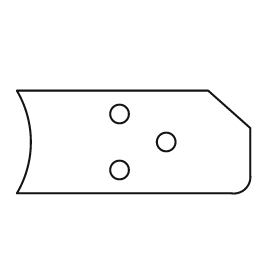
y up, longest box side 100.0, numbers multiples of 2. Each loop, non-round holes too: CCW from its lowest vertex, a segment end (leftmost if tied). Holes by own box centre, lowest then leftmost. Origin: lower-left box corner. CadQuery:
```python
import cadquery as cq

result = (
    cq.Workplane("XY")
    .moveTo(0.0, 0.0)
    .lineTo(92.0, 0.0)
    .threePointArc((98.0, 2.0), (100.0, 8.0))
    .lineTo(100.0, 28.0)
    .lineTo(82.0, 44.0)
    .lineTo(0.0, 44.0)
    .threePointArc((6.0, 22.0), (0.0, 0.0))
    .close()
    .moveTo(44.0, 10.0)
    .circle(4.0)
    .moveTo(64.0, 22.0)
    .circle(4.0)
    .moveTo(44.0, 34.0)
    .circle(4.0)
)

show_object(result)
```